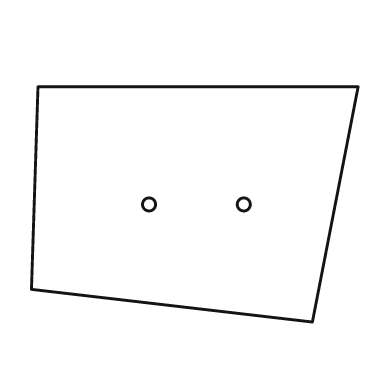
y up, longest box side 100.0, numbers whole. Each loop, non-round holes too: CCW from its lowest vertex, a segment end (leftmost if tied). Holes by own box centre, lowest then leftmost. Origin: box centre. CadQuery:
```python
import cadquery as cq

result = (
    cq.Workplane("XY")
    .moveTo(36.0, -36.0)
    .lineTo(50.0, 36.0)
    .lineTo(-48.0, 36.0)
    .lineTo(-50.0, -26.0)
    .close()
    .moveTo(-14.0, 0.0)
    .circle(2.0)
    .moveTo(15.0, 0.0)
    .circle(2.0)
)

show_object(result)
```